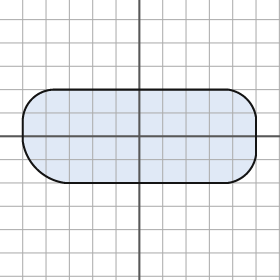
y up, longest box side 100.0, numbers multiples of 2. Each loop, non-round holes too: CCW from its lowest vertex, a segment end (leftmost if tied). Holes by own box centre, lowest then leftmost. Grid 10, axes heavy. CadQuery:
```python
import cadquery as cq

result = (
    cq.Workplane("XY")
    .moveTo(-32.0, -20.0)
    .lineTo(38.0, -20.0)
    .threePointArc((46.0, -16.0), (50.0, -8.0))
    .lineTo(50.0, 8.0)
    .threePointArc((46.0, 16.0), (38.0, 20.0))
    .lineTo(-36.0, 20.0)
    .threePointArc((-46.0, 16.0), (-50.0, 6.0))
    .lineTo(-50.0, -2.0)
    .threePointArc((-44.0, -14.0), (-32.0, -20.0))
    .close()
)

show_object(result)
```